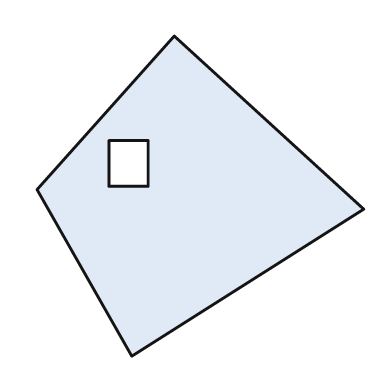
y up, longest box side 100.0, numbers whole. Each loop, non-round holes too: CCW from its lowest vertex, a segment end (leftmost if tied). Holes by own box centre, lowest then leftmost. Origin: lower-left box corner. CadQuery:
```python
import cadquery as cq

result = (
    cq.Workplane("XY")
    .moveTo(29.0, 0.0)
    .lineTo(100.0, 45.0)
    .lineTo(42.0, 98.0)
    .lineTo(0.0, 51.0)
    .close()
    .moveTo(22.0, 52.0)
    .lineTo(34.0, 52.0)
    .lineTo(34.0, 66.0)
    .lineTo(22.0, 66.0)
    .close()
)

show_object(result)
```